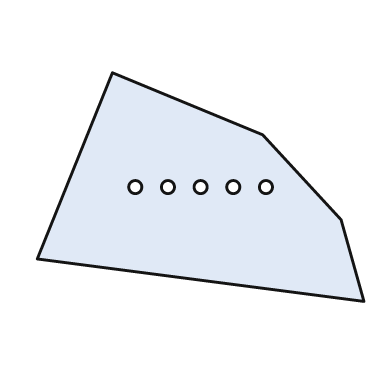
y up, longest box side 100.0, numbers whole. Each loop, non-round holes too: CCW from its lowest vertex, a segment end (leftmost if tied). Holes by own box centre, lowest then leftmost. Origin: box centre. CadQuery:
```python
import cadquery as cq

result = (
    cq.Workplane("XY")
    .moveTo(50.0, -35.0)
    .lineTo(43.0, -10.0)
    .lineTo(19.0, 16.0)
    .lineTo(-27.0, 35.0)
    .lineTo(-50.0, -22.0)
    .close()
    .moveTo(-20.0, 0.0)
    .circle(2.0)
    .moveTo(-10.0, 0.0)
    .circle(2.0)
    .moveTo(0.0, 0.0)
    .circle(2.0)
    .moveTo(10.0, 0.0)
    .circle(2.0)
    .moveTo(20.0, 0.0)
    .circle(2.0)
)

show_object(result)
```